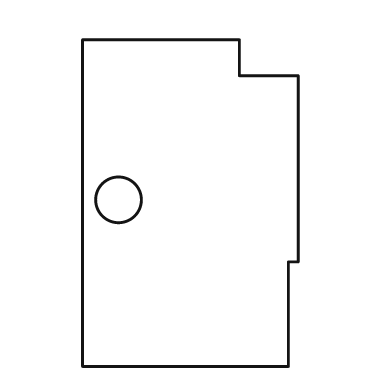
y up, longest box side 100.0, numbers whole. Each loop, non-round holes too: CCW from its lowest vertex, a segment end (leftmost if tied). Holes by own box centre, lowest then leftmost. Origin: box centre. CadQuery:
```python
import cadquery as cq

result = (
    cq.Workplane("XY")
    .moveTo(-33.0, -50.0)
    .lineTo(30.0, -50.0)
    .lineTo(30.0, -18.0)
    .lineTo(33.0, -18.0)
    .lineTo(33.0, 39.0)
    .lineTo(15.0, 39.0)
    .lineTo(15.0, 50.0)
    .lineTo(-33.0, 50.0)
    .close()
    .moveTo(-22.0, 1.0)
    .circle(7.0)
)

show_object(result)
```